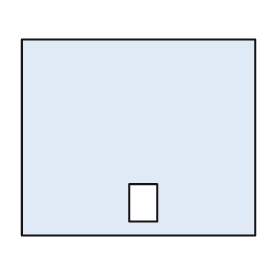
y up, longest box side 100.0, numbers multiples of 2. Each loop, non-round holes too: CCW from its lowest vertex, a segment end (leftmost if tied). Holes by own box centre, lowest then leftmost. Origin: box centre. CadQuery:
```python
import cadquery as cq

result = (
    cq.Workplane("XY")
    .moveTo(-50.0, -42.0)
    .lineTo(50.0, -42.0)
    .lineTo(50.0, 42.0)
    .lineTo(-50.0, 42.0)
    .close()
    .moveTo(-4.0, -36.0)
    .lineTo(8.0, -36.0)
    .lineTo(8.0, -20.0)
    .lineTo(-4.0, -20.0)
    .close()
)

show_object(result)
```